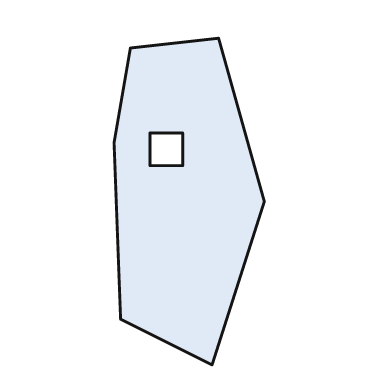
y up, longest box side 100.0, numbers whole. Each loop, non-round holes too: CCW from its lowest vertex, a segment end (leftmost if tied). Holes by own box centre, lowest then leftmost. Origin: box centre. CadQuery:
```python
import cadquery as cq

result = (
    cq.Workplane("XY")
    .moveTo(7.0, -50.0)
    .lineTo(23.0, 0.0)
    .lineTo(9.0, 50.0)
    .lineTo(-18.0, 47.0)
    .lineTo(-23.0, 18.0)
    .lineTo(-21.0, -36.0)
    .close()
    .moveTo(-12.0, 11.0)
    .lineTo(-2.0, 11.0)
    .lineTo(-2.0, 21.0)
    .lineTo(-12.0, 21.0)
    .close()
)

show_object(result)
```